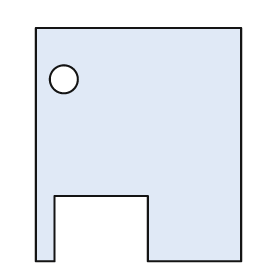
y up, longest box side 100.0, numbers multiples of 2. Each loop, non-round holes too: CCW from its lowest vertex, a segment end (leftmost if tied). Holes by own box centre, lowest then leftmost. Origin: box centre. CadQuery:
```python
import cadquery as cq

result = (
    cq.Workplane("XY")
    .moveTo(-44.0, -50.0)
    .lineTo(-36.0, -50.0)
    .lineTo(-36.0, -22.0)
    .lineTo(4.0, -22.0)
    .lineTo(4.0, -50.0)
    .lineTo(44.0, -50.0)
    .lineTo(44.0, 50.0)
    .lineTo(-44.0, 50.0)
    .close()
    .moveTo(-32.0, 28.0)
    .circle(6.0)
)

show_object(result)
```